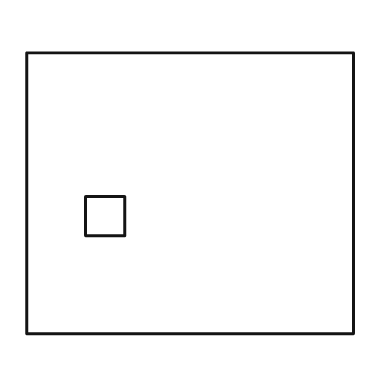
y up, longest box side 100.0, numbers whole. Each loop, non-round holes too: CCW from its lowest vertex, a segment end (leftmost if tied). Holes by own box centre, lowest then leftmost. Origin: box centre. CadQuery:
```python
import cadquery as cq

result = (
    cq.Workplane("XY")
    .moveTo(-50.0, -43.0)
    .lineTo(50.0, -43.0)
    .lineTo(50.0, 43.0)
    .lineTo(-50.0, 43.0)
    .close()
    .moveTo(-32.0, -13.0)
    .lineTo(-20.0, -13.0)
    .lineTo(-20.0, -1.0)
    .lineTo(-32.0, -1.0)
    .close()
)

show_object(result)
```